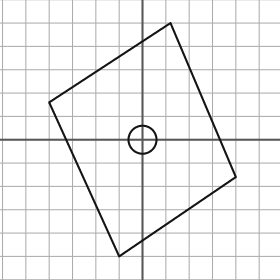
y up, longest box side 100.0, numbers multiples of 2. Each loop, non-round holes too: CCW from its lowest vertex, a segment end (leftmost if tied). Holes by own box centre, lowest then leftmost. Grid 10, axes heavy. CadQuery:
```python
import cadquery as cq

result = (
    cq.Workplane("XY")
    .moveTo(-10.0, -50.0)
    .lineTo(40.0, -16.0)
    .lineTo(12.0, 50.0)
    .lineTo(-40.0, 16.0)
    .close()
    .moveTo(0.0, 0.0)
    .circle(6.0)
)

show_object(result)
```